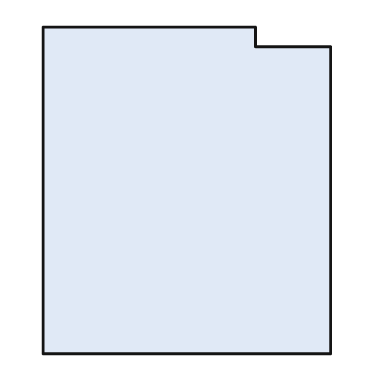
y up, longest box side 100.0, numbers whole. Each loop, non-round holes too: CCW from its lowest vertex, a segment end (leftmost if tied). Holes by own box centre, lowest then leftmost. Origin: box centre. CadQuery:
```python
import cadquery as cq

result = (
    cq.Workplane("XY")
    .moveTo(-44.0, -50.0)
    .lineTo(44.0, -50.0)
    .lineTo(44.0, 44.0)
    .lineTo(21.0, 44.0)
    .lineTo(21.0, 50.0)
    .lineTo(-44.0, 50.0)
    .close()
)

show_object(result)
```